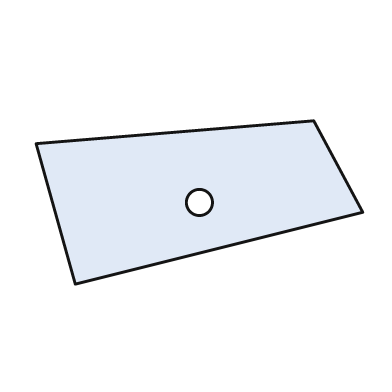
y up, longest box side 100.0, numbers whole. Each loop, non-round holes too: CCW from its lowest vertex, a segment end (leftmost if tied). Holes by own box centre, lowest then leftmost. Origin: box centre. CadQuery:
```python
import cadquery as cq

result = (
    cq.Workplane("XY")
    .moveTo(-38.0, -25.0)
    .lineTo(50.0, -3.0)
    .lineTo(35.0, 25.0)
    .lineTo(-50.0, 18.0)
    .close()
    .moveTo(0.0, 0.0)
    .circle(4.0)
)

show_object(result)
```